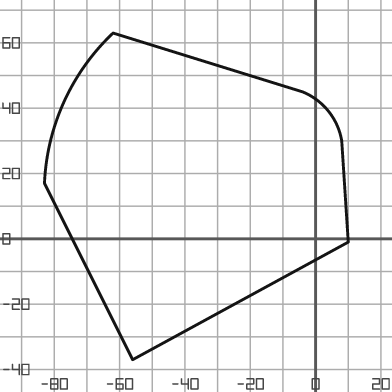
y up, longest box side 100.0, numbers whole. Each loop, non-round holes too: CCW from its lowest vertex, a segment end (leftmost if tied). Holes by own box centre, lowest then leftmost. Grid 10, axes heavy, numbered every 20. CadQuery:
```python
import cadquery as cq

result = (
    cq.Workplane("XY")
    .moveTo(-56.0, -37.0)
    .lineTo(10.0, -1.0)
    .lineTo(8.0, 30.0)
    .threePointArc((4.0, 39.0), (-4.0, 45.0))
    .lineTo(-62.0, 63.0)
    .threePointArc((-77.0, 42.0), (-83.0, 17.0))
    .close()
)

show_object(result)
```